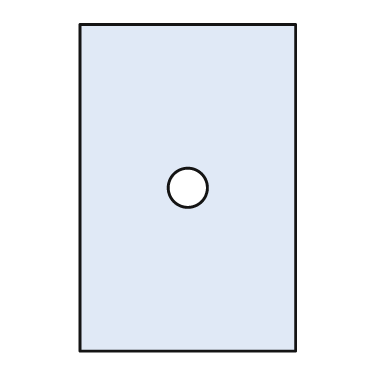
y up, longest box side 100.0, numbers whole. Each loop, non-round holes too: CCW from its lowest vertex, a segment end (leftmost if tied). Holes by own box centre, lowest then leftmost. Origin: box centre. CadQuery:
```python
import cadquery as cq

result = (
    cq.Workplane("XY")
    .moveTo(-33.0, -50.0)
    .lineTo(33.0, -50.0)
    .lineTo(33.0, 50.0)
    .lineTo(-33.0, 50.0)
    .close()
    .moveTo(0.0, 0.0)
    .circle(6.0)
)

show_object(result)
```